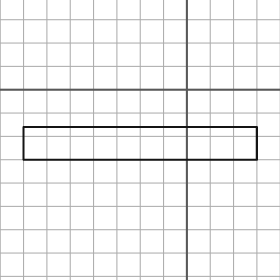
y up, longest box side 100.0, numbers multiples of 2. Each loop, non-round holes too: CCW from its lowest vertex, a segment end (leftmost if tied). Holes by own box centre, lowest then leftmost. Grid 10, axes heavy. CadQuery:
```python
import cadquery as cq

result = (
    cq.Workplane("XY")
    .moveTo(-70.0, -30.0)
    .lineTo(30.0, -30.0)
    .lineTo(30.0, -16.0)
    .lineTo(-70.0, -16.0)
    .close()
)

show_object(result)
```